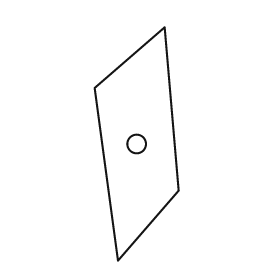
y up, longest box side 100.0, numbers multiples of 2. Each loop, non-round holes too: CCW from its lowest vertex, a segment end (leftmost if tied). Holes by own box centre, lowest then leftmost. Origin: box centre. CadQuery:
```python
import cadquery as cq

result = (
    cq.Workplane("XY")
    .moveTo(-8.0, -50.0)
    .lineTo(18.0, -20.0)
    .lineTo(12.0, 50.0)
    .lineTo(-18.0, 24.0)
    .close()
    .moveTo(0.0, 0.0)
    .circle(4.0)
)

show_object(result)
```